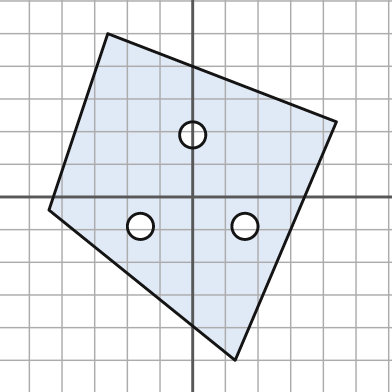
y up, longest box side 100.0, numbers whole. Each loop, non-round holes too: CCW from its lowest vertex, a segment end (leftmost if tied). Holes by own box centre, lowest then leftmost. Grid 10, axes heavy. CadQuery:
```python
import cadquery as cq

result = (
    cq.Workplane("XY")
    .moveTo(13.0, -50.0)
    .lineTo(44.0, 23.0)
    .lineTo(-26.0, 50.0)
    .lineTo(-44.0, -4.0)
    .close()
    .moveTo(-16.0, -9.0)
    .circle(4.0)
    .moveTo(16.0, -9.0)
    .circle(4.0)
    .moveTo(0.0, 19.0)
    .circle(4.0)
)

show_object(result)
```